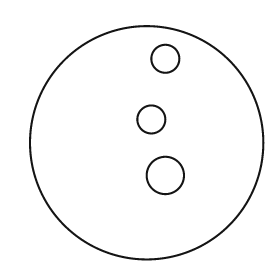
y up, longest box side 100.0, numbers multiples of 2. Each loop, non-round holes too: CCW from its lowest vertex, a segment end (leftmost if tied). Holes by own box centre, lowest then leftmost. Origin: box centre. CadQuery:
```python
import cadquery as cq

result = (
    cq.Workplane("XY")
    .moveTo(0.0, 0.0)
    .circle(50.0)
    .moveTo(8.0, -14.0)
    .circle(8.0)
    .moveTo(2.0, 10.0)
    .circle(6.0)
    .moveTo(8.0, 36.0)
    .circle(6.0)
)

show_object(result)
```